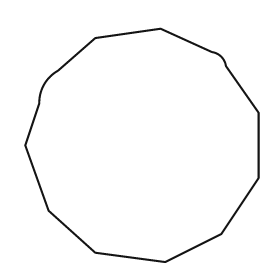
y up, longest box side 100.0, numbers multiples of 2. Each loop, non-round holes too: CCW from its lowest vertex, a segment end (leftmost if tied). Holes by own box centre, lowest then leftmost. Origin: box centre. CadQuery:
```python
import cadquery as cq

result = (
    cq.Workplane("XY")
    .moveTo(10.0, -50.0)
    .lineTo(34.0, -38.0)
    .lineTo(50.0, -14.0)
    .lineTo(50.0, 14.0)
    .lineTo(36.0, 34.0)
    .threePointArc((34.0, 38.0), (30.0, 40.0))
    .lineTo(8.0, 50.0)
    .lineTo(-20.0, 46.0)
    .lineTo(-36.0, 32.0)
    .threePointArc((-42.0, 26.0), (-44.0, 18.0))
    .lineTo(-50.0, 0.0)
    .lineTo(-40.0, -28.0)
    .lineTo(-20.0, -46.0)
    .close()
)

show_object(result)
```